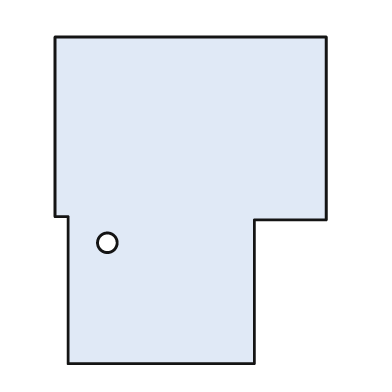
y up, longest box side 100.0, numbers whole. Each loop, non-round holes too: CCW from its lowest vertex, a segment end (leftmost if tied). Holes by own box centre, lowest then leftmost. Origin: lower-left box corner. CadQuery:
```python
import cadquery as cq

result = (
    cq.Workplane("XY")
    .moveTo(4.0, 0.0)
    .lineTo(61.0, 0.0)
    .lineTo(61.0, 44.0)
    .lineTo(83.0, 44.0)
    .lineTo(83.0, 100.0)
    .lineTo(0.0, 100.0)
    .lineTo(0.0, 45.0)
    .lineTo(4.0, 45.0)
    .close()
    .moveTo(16.0, 37.0)
    .circle(3.0)
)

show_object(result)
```